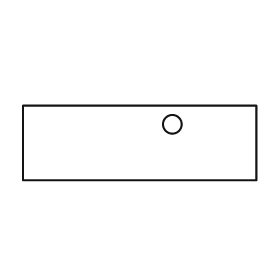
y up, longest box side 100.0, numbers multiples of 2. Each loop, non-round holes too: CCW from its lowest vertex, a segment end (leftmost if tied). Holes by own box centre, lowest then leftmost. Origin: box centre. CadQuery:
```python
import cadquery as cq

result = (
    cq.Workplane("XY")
    .moveTo(-50.0, -16.0)
    .lineTo(50.0, -16.0)
    .lineTo(50.0, 16.0)
    .lineTo(-50.0, 16.0)
    .close()
    .moveTo(14.0, 8.0)
    .circle(4.0)
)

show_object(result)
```